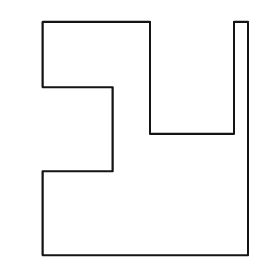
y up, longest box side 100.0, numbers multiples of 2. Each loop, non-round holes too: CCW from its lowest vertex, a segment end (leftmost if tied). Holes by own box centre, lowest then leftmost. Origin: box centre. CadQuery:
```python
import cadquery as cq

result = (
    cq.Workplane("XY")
    .moveTo(-44.0, -50.0)
    .lineTo(44.0, -50.0)
    .lineTo(44.0, 50.0)
    .lineTo(38.0, 50.0)
    .lineTo(38.0, 2.0)
    .lineTo(2.0, 2.0)
    .lineTo(2.0, 50.0)
    .lineTo(-44.0, 50.0)
    .lineTo(-44.0, 22.0)
    .lineTo(-14.0, 22.0)
    .lineTo(-14.0, -14.0)
    .lineTo(-44.0, -14.0)
    .close()
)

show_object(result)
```